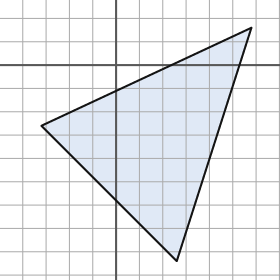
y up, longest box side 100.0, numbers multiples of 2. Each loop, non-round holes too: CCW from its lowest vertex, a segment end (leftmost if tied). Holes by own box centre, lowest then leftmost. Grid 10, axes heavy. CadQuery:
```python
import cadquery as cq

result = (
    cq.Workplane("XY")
    .moveTo(26.0, -84.0)
    .lineTo(58.0, 16.0)
    .lineTo(-32.0, -26.0)
    .close()
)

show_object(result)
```